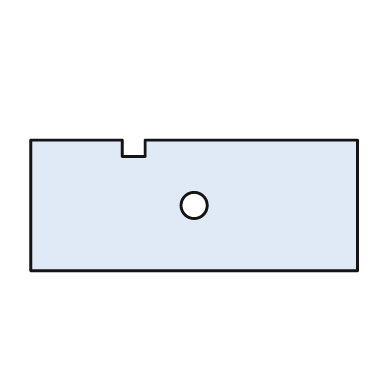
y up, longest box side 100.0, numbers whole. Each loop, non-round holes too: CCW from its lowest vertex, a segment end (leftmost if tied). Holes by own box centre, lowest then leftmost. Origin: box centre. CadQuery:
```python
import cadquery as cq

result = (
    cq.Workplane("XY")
    .moveTo(-50.0, -20.0)
    .lineTo(50.0, -20.0)
    .lineTo(50.0, 20.0)
    .lineTo(-15.0, 20.0)
    .lineTo(-15.0, 15.0)
    .lineTo(-22.0, 15.0)
    .lineTo(-22.0, 20.0)
    .lineTo(-50.0, 20.0)
    .close()
    .moveTo(0.0, 0.0)
    .circle(4.0)
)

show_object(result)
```